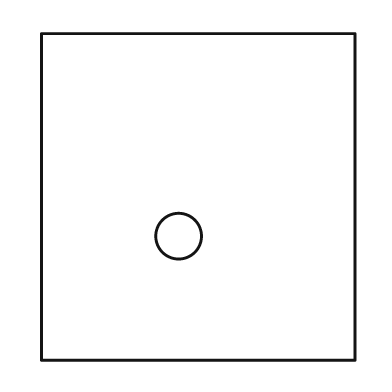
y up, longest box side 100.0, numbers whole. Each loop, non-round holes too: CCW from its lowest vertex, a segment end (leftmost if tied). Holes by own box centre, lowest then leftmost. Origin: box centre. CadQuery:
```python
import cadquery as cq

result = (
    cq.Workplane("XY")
    .moveTo(-48.0, -50.0)
    .lineTo(48.0, -50.0)
    .lineTo(48.0, 50.0)
    .lineTo(-48.0, 50.0)
    .close()
    .moveTo(-6.0, -12.0)
    .circle(7.0)
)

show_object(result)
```